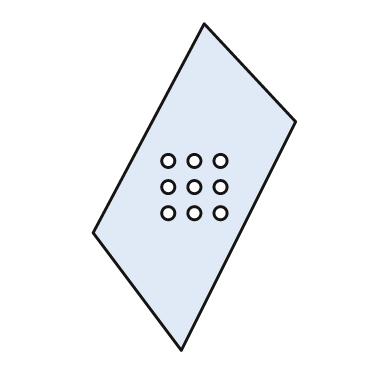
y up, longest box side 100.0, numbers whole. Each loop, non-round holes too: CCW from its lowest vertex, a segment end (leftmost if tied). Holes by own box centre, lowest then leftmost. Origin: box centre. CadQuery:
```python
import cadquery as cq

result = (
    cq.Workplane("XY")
    .moveTo(-4.0, -50.0)
    .lineTo(31.0, 20.0)
    .lineTo(3.0, 50.0)
    .lineTo(-31.0, -14.0)
    .close()
    .moveTo(-8.0, -8.0)
    .circle(2.0)
    .moveTo(0.0, -8.0)
    .circle(2.0)
    .moveTo(8.0, -8.0)
    .circle(2.0)
    .moveTo(-8.0, 0.0)
    .circle(2.0)
    .moveTo(0.0, 0.0)
    .circle(2.0)
    .moveTo(8.0, 0.0)
    .circle(2.0)
    .moveTo(-8.0, 8.0)
    .circle(2.0)
    .moveTo(0.0, 8.0)
    .circle(2.0)
    .moveTo(8.0, 8.0)
    .circle(2.0)
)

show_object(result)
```